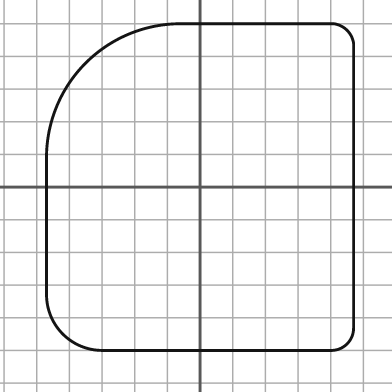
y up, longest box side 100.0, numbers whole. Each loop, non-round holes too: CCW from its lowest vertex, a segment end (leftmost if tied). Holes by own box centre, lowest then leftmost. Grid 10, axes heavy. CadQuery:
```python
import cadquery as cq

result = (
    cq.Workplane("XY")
    .moveTo(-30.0, -50.0)
    .lineTo(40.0, -50.0)
    .threePointArc((45.0, -48.0), (47.0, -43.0))
    .lineTo(47.0, 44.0)
    .threePointArc((45.0, 48.0), (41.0, 50.0))
    .lineTo(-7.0, 50.0)
    .threePointArc((-35.0, 38.0), (-47.0, 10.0))
    .lineTo(-47.0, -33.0)
    .threePointArc((-42.0, -45.0), (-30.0, -50.0))
    .close()
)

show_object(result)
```